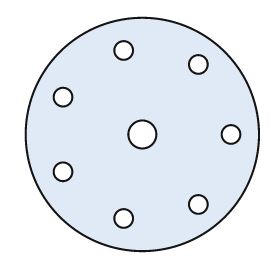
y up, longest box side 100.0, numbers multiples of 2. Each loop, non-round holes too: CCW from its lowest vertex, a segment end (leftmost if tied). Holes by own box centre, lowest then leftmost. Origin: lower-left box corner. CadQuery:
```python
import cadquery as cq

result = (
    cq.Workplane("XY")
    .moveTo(50.0, 50.0)
    .circle(50.0)
    .moveTo(42.0, 14.0)
    .circle(4.0)
    .moveTo(74.0, 20.0)
    .circle(4.0)
    .moveTo(16.0, 34.0)
    .circle(4.0)
    .moveTo(50.0, 50.0)
    .circle(6.0)
    .moveTo(88.0, 50.0)
    .circle(4.0)
    .moveTo(16.0, 66.0)
    .circle(4.0)
    .moveTo(74.0, 80.0)
    .circle(4.0)
    .moveTo(42.0, 86.0)
    .circle(4.0)
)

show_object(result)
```